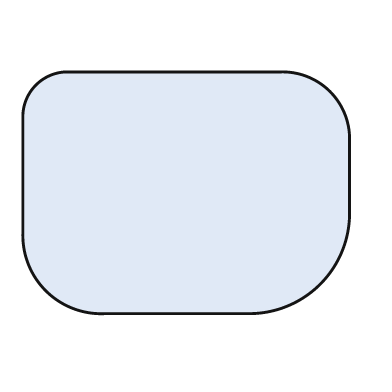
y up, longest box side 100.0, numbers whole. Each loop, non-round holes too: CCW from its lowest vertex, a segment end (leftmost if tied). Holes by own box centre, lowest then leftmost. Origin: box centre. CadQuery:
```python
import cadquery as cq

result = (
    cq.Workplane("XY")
    .moveTo(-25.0, -37.0)
    .lineTo(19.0, -37.0)
    .threePointArc((41.0, -28.0), (50.0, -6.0))
    .lineTo(50.0, 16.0)
    .threePointArc((44.0, 31.0), (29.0, 37.0))
    .lineTo(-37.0, 37.0)
    .threePointArc((-46.0, 33.0), (-50.0, 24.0))
    .lineTo(-50.0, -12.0)
    .threePointArc((-43.0, -30.0), (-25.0, -37.0))
    .close()
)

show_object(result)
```